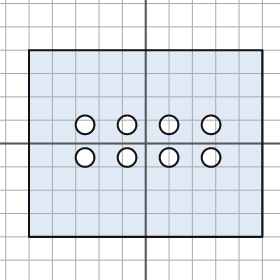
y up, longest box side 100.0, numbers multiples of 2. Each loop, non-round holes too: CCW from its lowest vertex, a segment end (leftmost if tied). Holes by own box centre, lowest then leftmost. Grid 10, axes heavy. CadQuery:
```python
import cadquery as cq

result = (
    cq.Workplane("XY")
    .moveTo(-50.0, -40.0)
    .lineTo(50.0, -40.0)
    .lineTo(50.0, 40.0)
    .lineTo(-50.0, 40.0)
    .close()
    .moveTo(-26.0, -6.0)
    .circle(4.0)
    .moveTo(-8.0, -6.0)
    .circle(4.0)
    .moveTo(10.0, -6.0)
    .circle(4.0)
    .moveTo(28.0, -6.0)
    .circle(4.0)
    .moveTo(-26.0, 8.0)
    .circle(4.0)
    .moveTo(-8.0, 8.0)
    .circle(4.0)
    .moveTo(10.0, 8.0)
    .circle(4.0)
    .moveTo(28.0, 8.0)
    .circle(4.0)
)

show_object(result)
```